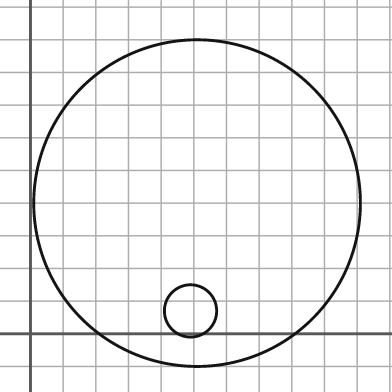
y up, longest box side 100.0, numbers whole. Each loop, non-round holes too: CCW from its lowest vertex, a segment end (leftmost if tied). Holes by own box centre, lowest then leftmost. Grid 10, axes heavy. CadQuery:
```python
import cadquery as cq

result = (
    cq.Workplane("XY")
    .moveTo(51.0, 40.0)
    .circle(50.0)
    .moveTo(49.0, 7.0)
    .circle(8.0)
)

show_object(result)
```